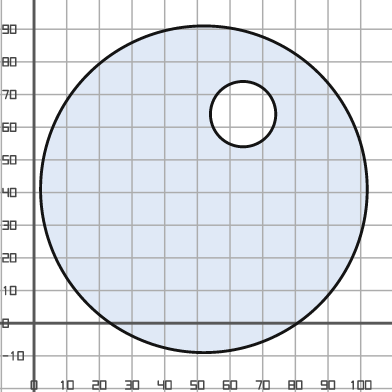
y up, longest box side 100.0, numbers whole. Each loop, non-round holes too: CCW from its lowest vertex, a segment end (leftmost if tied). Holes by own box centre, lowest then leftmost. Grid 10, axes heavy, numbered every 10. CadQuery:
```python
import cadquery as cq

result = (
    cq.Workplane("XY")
    .moveTo(52.0, 41.0)
    .circle(50.0)
    .moveTo(64.0, 64.0)
    .circle(10.0)
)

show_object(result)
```